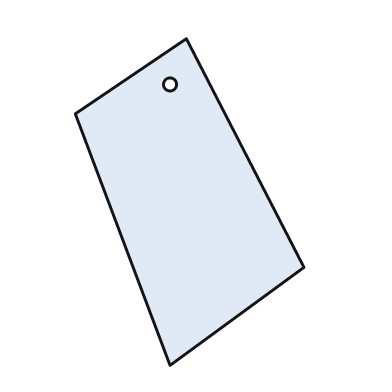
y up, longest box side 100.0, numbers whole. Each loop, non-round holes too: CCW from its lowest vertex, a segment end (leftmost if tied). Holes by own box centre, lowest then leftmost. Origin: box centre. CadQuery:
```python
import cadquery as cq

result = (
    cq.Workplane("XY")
    .moveTo(-6.0, -50.0)
    .lineTo(35.0, -20.0)
    .lineTo(-1.0, 50.0)
    .lineTo(-35.0, 27.0)
    .close()
    .moveTo(-6.0, 36.0)
    .circle(2.0)
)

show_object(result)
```